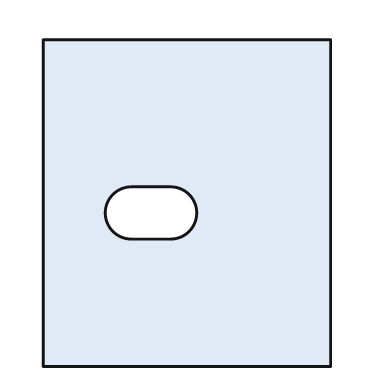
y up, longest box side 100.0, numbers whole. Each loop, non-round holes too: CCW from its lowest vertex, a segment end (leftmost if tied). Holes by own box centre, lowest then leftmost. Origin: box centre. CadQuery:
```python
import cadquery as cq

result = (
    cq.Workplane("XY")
    .moveTo(-44.0, -50.0)
    .lineTo(44.0, -50.0)
    .lineTo(44.0, 50.0)
    .lineTo(-44.0, 50.0)
    .close()
    .moveTo(-17.0, -11.0)
    .lineTo(-5.0, -11.0)
    .threePointArc((3.0, -3.0), (-5.0, 5.0))
    .lineTo(-17.0, 5.0)
    .threePointArc((-25.0, -3.0), (-17.0, -11.0))
    .close()
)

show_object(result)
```